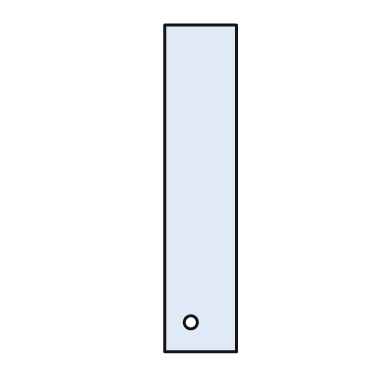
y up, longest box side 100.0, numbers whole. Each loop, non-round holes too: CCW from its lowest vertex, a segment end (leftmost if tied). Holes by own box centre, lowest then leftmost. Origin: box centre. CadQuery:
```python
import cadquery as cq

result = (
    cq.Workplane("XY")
    .moveTo(-11.0, -50.0)
    .lineTo(11.0, -50.0)
    .lineTo(11.0, 50.0)
    .lineTo(-11.0, 50.0)
    .close()
    .moveTo(-3.0, -41.0)
    .circle(2.0)
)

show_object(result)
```